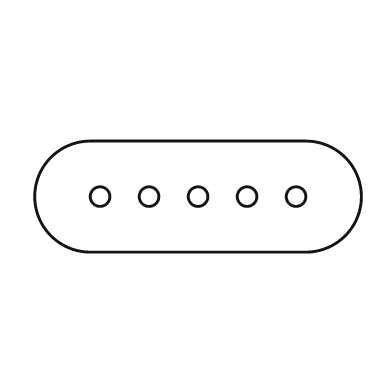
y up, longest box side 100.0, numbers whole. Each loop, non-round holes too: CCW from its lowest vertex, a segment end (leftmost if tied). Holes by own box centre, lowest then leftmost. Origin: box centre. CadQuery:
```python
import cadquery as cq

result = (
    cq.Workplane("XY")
    .moveTo(-33.0, -17.0)
    .lineTo(33.0, -17.0)
    .threePointArc((50.0, 0.0), (33.0, 17.0))
    .lineTo(-33.0, 17.0)
    .threePointArc((-50.0, 0.0), (-33.0, -17.0))
    .close()
    .moveTo(-30.0, 0.0)
    .circle(3.0)
    .moveTo(-15.0, 0.0)
    .circle(3.0)
    .moveTo(0.0, 0.0)
    .circle(3.0)
    .moveTo(15.0, 0.0)
    .circle(3.0)
    .moveTo(30.0, 0.0)
    .circle(3.0)
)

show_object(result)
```